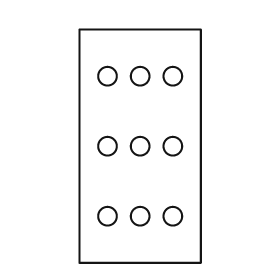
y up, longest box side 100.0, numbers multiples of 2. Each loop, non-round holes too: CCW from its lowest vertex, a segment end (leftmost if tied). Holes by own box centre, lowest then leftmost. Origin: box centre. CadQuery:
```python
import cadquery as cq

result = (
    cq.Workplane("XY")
    .moveTo(-26.0, -50.0)
    .lineTo(26.0, -50.0)
    .lineTo(26.0, 50.0)
    .lineTo(-26.0, 50.0)
    .close()
    .moveTo(-14.0, -30.0)
    .circle(4.0)
    .moveTo(0.0, -30.0)
    .circle(4.0)
    .moveTo(14.0, -30.0)
    .circle(4.0)
    .moveTo(-14.0, 0.0)
    .circle(4.0)
    .moveTo(0.0, 0.0)
    .circle(4.0)
    .moveTo(14.0, 0.0)
    .circle(4.0)
    .moveTo(-14.0, 30.0)
    .circle(4.0)
    .moveTo(0.0, 30.0)
    .circle(4.0)
    .moveTo(14.0, 30.0)
    .circle(4.0)
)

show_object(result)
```